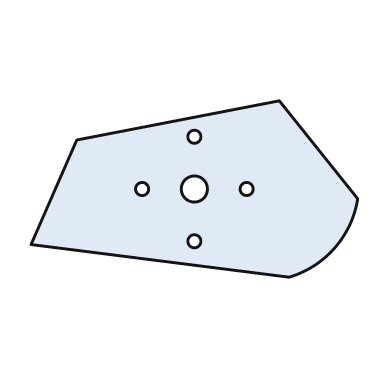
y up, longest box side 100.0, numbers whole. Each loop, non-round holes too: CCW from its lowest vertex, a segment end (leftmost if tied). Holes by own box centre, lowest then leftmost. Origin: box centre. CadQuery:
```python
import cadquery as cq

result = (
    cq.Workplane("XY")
    .moveTo(29.0, -27.0)
    .threePointArc((43.0, -18.0), (50.0, -3.0))
    .lineTo(26.0, 27.0)
    .lineTo(-36.0, 15.0)
    .lineTo(-50.0, -17.0)
    .close()
    .moveTo(0.0, -16.0)
    .circle(2.0)
    .moveTo(-16.0, 0.0)
    .circle(2.0)
    .moveTo(0.0, 0.0)
    .circle(4.0)
    .moveTo(16.0, 0.0)
    .circle(2.0)
    .moveTo(0.0, 16.0)
    .circle(2.0)
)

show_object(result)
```